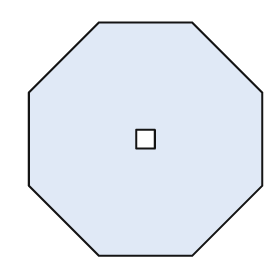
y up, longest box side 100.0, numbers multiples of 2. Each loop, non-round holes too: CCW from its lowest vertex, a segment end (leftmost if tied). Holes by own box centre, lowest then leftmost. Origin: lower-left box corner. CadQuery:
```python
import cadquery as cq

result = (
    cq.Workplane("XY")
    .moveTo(30.0, 0.0)
    .lineTo(70.0, 0.0)
    .lineTo(100.0, 30.0)
    .lineTo(100.0, 70.0)
    .lineTo(70.0, 100.0)
    .lineTo(30.0, 100.0)
    .lineTo(0.0, 70.0)
    .lineTo(0.0, 30.0)
    .close()
    .moveTo(46.0, 46.0)
    .lineTo(54.0, 46.0)
    .lineTo(54.0, 54.0)
    .lineTo(46.0, 54.0)
    .close()
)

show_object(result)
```